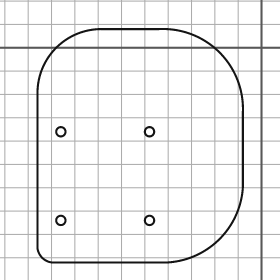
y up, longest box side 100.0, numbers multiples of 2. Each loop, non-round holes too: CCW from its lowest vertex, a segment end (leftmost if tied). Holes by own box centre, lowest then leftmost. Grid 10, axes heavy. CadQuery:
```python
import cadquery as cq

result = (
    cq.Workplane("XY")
    .moveTo(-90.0, -92.0)
    .lineTo(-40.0, -92.0)
    .threePointArc((-18.0, -82.0), (-8.0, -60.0))
    .lineTo(-8.0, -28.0)
    .threePointArc((-18.0, -2.0), (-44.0, 8.0))
    .lineTo(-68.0, 8.0)
    .threePointArc((-88.0, 0.0), (-96.0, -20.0))
    .lineTo(-96.0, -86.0)
    .threePointArc((-94.0, -90.0), (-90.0, -92.0))
    .close()
    .moveTo(-86.0, -74.0)
    .circle(2.0)
    .moveTo(-48.0, -74.0)
    .circle(2.0)
    .moveTo(-86.0, -36.0)
    .circle(2.0)
    .moveTo(-48.0, -36.0)
    .circle(2.0)
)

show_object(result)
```